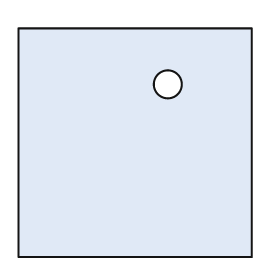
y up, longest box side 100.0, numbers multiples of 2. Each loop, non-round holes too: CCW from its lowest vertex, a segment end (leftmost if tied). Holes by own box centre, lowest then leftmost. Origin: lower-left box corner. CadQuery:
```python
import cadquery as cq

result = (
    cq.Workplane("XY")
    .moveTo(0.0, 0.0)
    .lineTo(100.0, 0.0)
    .lineTo(100.0, 98.0)
    .lineTo(0.0, 98.0)
    .close()
    .moveTo(64.0, 74.0)
    .circle(6.0)
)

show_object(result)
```